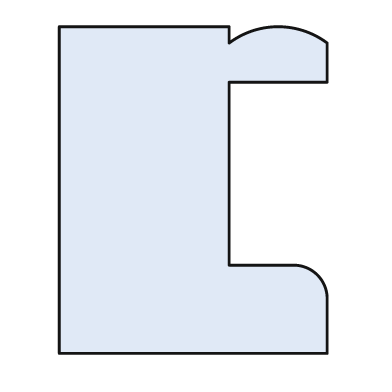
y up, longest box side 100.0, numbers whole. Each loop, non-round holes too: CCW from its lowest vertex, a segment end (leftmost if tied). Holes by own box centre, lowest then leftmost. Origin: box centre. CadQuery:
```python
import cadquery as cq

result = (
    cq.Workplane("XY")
    .moveTo(-41.0, -50.0)
    .lineTo(41.0, -50.0)
    .lineTo(41.0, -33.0)
    .threePointArc((38.0, -26.0), (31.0, -23.0))
    .lineTo(11.0, -23.0)
    .lineTo(11.0, 33.0)
    .lineTo(41.0, 33.0)
    .lineTo(41.0, 45.0)
    .threePointArc((26.0, 50.0), (11.0, 45.0))
    .lineTo(11.0, 50.0)
    .lineTo(-41.0, 50.0)
    .close()
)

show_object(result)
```